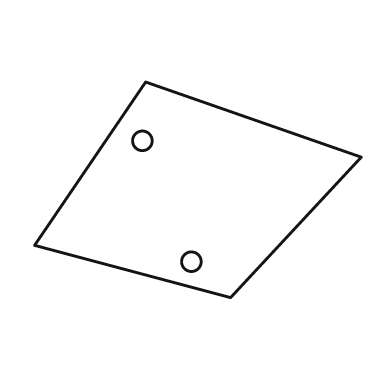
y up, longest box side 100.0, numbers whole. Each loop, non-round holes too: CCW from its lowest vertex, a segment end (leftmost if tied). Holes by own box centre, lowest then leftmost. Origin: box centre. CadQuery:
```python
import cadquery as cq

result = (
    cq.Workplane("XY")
    .moveTo(10.0, -33.0)
    .lineTo(50.0, 10.0)
    .lineTo(-16.0, 33.0)
    .lineTo(-50.0, -17.0)
    .close()
    .moveTo(-2.0, -22.0)
    .circle(3.0)
    .moveTo(-17.0, 15.0)
    .circle(3.0)
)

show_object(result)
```